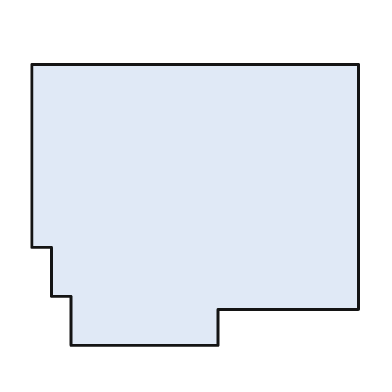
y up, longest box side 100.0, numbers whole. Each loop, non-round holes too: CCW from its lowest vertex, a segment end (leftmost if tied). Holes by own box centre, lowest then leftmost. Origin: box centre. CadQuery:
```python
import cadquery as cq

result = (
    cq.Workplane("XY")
    .moveTo(-38.0, -43.0)
    .lineTo(7.0, -43.0)
    .lineTo(7.0, -32.0)
    .lineTo(50.0, -32.0)
    .lineTo(50.0, 43.0)
    .lineTo(-50.0, 43.0)
    .lineTo(-50.0, -13.0)
    .lineTo(-44.0, -13.0)
    .lineTo(-44.0, -28.0)
    .lineTo(-38.0, -28.0)
    .close()
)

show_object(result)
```